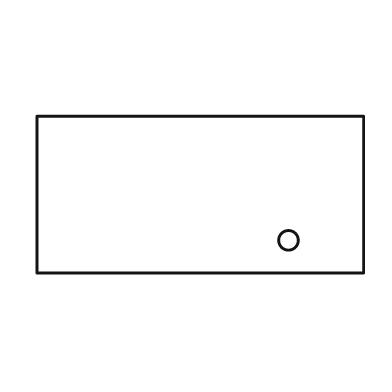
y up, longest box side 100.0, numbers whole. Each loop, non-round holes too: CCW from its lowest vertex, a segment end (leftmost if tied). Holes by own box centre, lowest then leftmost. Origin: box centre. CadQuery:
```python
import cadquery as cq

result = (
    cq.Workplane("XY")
    .moveTo(-50.0, -24.0)
    .lineTo(50.0, -24.0)
    .lineTo(50.0, 24.0)
    .lineTo(-50.0, 24.0)
    .close()
    .moveTo(27.0, -14.0)
    .circle(3.0)
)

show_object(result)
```